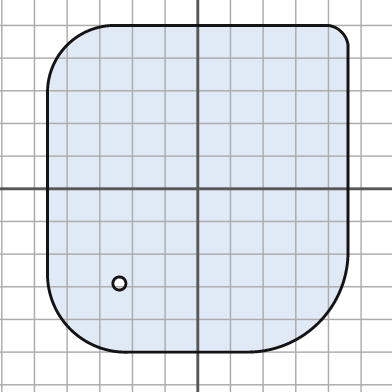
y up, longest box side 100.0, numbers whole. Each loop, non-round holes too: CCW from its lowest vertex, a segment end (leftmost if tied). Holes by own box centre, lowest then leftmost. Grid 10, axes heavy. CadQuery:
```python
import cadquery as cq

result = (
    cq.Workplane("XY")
    .moveTo(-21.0, -50.0)
    .lineTo(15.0, -50.0)
    .threePointArc((37.0, -41.0), (46.0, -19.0))
    .lineTo(46.0, 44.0)
    .threePointArc((44.0, 48.0), (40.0, 50.0))
    .lineTo(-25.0, 50.0)
    .threePointArc((-40.0, 44.0), (-46.0, 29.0))
    .lineTo(-46.0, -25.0)
    .threePointArc((-39.0, -43.0), (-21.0, -50.0))
    .close()
    .moveTo(-24.0, -29.0)
    .circle(2.0)
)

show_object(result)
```